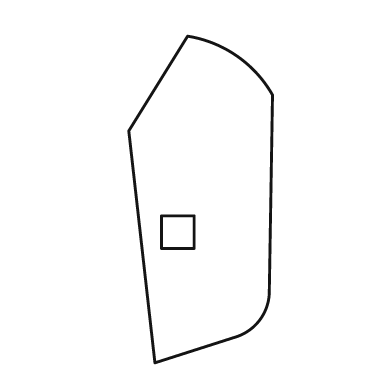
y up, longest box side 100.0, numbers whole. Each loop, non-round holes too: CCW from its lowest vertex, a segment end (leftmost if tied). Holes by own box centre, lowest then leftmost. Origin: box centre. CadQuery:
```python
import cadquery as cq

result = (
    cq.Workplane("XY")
    .moveTo(-14.0, -50.0)
    .lineTo(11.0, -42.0)
    .threePointArc((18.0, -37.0), (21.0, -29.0))
    .lineTo(22.0, 32.0)
    .threePointArc((11.0, 44.0), (-4.0, 50.0))
    .lineTo(-22.0, 21.0)
    .close()
    .moveTo(-12.0, -15.0)
    .lineTo(-2.0, -15.0)
    .lineTo(-2.0, -5.0)
    .lineTo(-12.0, -5.0)
    .close()
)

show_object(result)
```